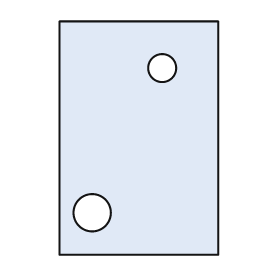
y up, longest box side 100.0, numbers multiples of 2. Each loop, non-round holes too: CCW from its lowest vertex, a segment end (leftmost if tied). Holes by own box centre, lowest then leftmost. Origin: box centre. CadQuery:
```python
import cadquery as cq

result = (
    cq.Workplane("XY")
    .moveTo(-34.0, -50.0)
    .lineTo(34.0, -50.0)
    .lineTo(34.0, 50.0)
    .lineTo(-34.0, 50.0)
    .close()
    .moveTo(-20.0, -32.0)
    .circle(8.0)
    .moveTo(10.0, 30.0)
    .circle(6.0)
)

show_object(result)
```